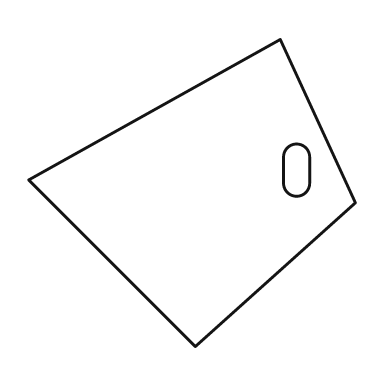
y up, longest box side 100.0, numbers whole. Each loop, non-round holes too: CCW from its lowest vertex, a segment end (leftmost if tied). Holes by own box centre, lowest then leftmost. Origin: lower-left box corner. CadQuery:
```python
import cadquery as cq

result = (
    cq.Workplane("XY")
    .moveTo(51.0, 0.0)
    .lineTo(100.0, 44.0)
    .lineTo(77.0, 94.0)
    .lineTo(0.0, 51.0)
    .close()
    .moveTo(78.0, 50.0)
    .threePointArc((82.0, 46.0), (86.0, 50.0))
    .lineTo(86.0, 58.0)
    .threePointArc((82.0, 62.0), (78.0, 58.0))
    .close()
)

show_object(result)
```